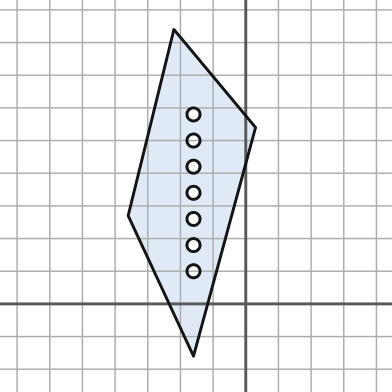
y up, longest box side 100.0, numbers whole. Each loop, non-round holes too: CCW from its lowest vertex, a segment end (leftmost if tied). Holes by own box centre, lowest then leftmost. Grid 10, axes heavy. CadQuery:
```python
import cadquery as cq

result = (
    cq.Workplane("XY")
    .moveTo(-16.0, -16.0)
    .lineTo(3.0, 54.0)
    .lineTo(-22.0, 84.0)
    .lineTo(-36.0, 27.0)
    .close()
    .moveTo(-16.0, 10.0)
    .circle(2.0)
    .moveTo(-16.0, 18.0)
    .circle(2.0)
    .moveTo(-16.0, 26.0)
    .circle(2.0)
    .moveTo(-16.0, 34.0)
    .circle(2.0)
    .moveTo(-16.0, 42.0)
    .circle(2.0)
    .moveTo(-16.0, 50.0)
    .circle(2.0)
    .moveTo(-16.0, 58.0)
    .circle(2.0)
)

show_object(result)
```